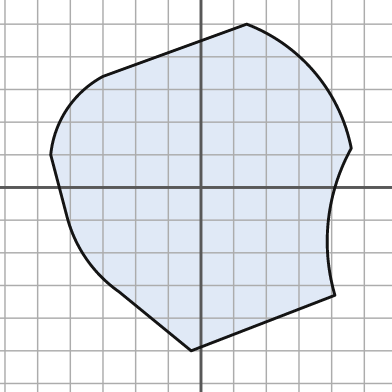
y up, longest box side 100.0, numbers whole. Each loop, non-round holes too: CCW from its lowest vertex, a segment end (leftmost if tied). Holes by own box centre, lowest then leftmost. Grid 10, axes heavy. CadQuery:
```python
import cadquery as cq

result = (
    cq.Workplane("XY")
    .moveTo(-3.0, -50.0)
    .lineTo(41.0, -33.0)
    .threePointArc((39.0, -10.0), (46.0, 12.0))
    .threePointArc((35.0, 35.0), (14.0, 50.0))
    .lineTo(-30.0, 34.0)
    .threePointArc((-41.0, 24.0), (-46.0, 10.0))
    .lineTo(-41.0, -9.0)
    .threePointArc((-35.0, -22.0), (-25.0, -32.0))
    .close()
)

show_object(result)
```